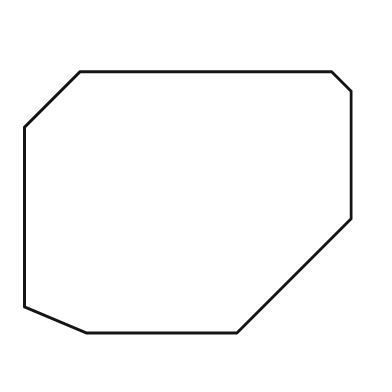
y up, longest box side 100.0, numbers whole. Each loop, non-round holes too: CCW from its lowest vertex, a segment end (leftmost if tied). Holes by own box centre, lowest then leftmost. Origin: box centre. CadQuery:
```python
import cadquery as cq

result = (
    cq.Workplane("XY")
    .moveTo(-31.0, -40.0)
    .lineTo(15.0, -40.0)
    .lineTo(50.0, -5.0)
    .lineTo(50.0, 34.0)
    .lineTo(44.0, 40.0)
    .lineTo(-33.0, 40.0)
    .lineTo(-50.0, 23.0)
    .lineTo(-50.0, -32.0)
    .close()
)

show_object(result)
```